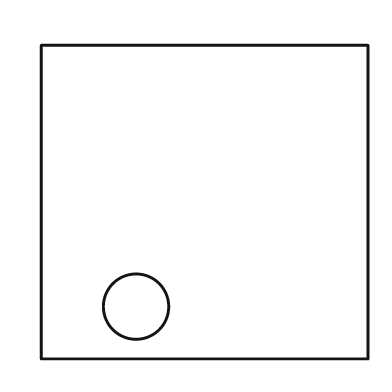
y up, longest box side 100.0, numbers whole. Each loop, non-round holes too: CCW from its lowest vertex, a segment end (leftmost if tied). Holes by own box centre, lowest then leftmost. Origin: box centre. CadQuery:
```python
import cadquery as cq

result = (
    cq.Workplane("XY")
    .moveTo(-50.0, -48.0)
    .lineTo(50.0, -48.0)
    .lineTo(50.0, 48.0)
    .lineTo(-50.0, 48.0)
    .close()
    .moveTo(-21.0, -32.0)
    .circle(10.0)
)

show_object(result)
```